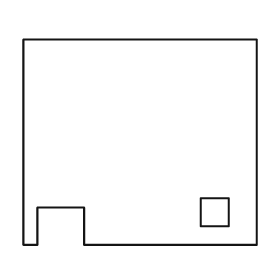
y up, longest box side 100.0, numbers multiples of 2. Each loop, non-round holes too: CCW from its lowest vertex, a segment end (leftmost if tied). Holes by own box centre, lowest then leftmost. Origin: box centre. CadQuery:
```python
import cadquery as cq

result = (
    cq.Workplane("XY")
    .moveTo(-50.0, -44.0)
    .lineTo(-44.0, -44.0)
    .lineTo(-44.0, -28.0)
    .lineTo(-24.0, -28.0)
    .lineTo(-24.0, -44.0)
    .lineTo(50.0, -44.0)
    .lineTo(50.0, 44.0)
    .lineTo(-50.0, 44.0)
    .close()
    .moveTo(26.0, -36.0)
    .lineTo(38.0, -36.0)
    .lineTo(38.0, -24.0)
    .lineTo(26.0, -24.0)
    .close()
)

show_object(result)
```